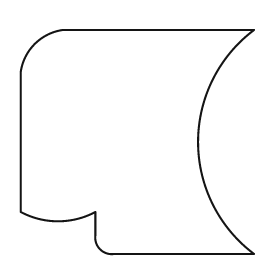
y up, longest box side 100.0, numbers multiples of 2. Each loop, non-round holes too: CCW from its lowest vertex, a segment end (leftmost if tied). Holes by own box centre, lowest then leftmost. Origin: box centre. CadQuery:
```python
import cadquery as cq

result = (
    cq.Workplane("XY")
    .moveTo(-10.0, -48.0)
    .lineTo(50.0, -48.0)
    .threePointArc((26.0, 0.0), (50.0, 48.0))
    .lineTo(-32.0, 48.0)
    .threePointArc((-44.0, 42.0), (-50.0, 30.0))
    .lineTo(-50.0, -30.0)
    .threePointArc((-34.0, -34.0), (-18.0, -30.0))
    .lineTo(-18.0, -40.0)
    .threePointArc((-16.0, -46.0), (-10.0, -48.0))
    .close()
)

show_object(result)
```